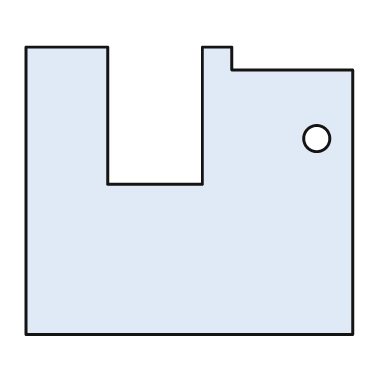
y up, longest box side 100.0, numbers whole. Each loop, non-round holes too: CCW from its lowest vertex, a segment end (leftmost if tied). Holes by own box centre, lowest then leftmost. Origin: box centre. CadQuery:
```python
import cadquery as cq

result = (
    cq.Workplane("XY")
    .moveTo(-50.0, -44.0)
    .lineTo(50.0, -44.0)
    .lineTo(50.0, 37.0)
    .lineTo(13.0, 37.0)
    .lineTo(13.0, 44.0)
    .lineTo(4.0, 44.0)
    .lineTo(4.0, 2.0)
    .lineTo(-25.0, 2.0)
    .lineTo(-25.0, 44.0)
    .lineTo(-50.0, 44.0)
    .close()
    .moveTo(39.0, 16.0)
    .circle(4.0)
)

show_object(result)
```